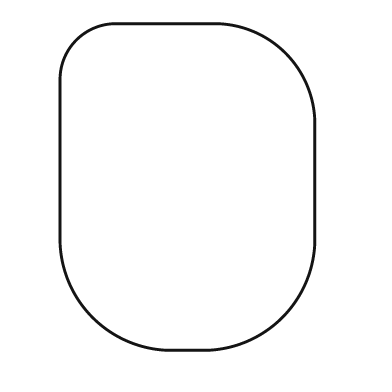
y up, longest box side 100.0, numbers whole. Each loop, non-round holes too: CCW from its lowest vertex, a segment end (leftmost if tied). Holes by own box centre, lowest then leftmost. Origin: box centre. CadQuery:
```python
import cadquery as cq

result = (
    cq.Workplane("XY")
    .moveTo(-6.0, -50.0)
    .lineTo(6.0, -50.0)
    .threePointArc((29.0, -40.0), (39.0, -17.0))
    .lineTo(39.0, 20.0)
    .threePointArc((30.0, 41.0), (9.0, 50.0))
    .lineTo(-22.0, 50.0)
    .threePointArc((-34.0, 45.0), (-39.0, 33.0))
    .lineTo(-39.0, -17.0)
    .threePointArc((-29.0, -40.0), (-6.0, -50.0))
    .close()
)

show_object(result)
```